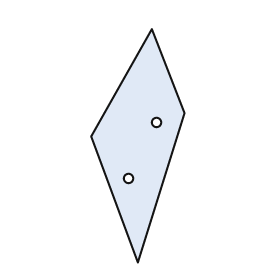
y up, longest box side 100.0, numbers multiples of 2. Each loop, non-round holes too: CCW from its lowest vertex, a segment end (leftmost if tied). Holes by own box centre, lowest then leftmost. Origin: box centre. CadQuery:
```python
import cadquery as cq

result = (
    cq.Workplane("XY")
    .moveTo(0.0, -50.0)
    .lineTo(20.0, 14.0)
    .lineTo(6.0, 50.0)
    .lineTo(-20.0, 4.0)
    .close()
    .moveTo(-4.0, -14.0)
    .circle(2.0)
    .moveTo(8.0, 10.0)
    .circle(2.0)
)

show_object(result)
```